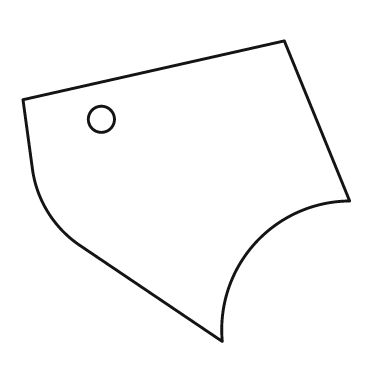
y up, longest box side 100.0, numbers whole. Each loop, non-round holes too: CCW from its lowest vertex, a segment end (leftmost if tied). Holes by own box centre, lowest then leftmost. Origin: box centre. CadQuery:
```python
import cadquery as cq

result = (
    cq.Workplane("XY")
    .moveTo(11.0, -46.0)
    .threePointArc((21.0, -16.0), (50.0, -3.0))
    .lineTo(30.0, 46.0)
    .lineTo(-50.0, 28.0)
    .lineTo(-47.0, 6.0)
    .threePointArc((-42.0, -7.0), (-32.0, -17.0))
    .close()
    .moveTo(-26.0, 22.0)
    .circle(4.0)
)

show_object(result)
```